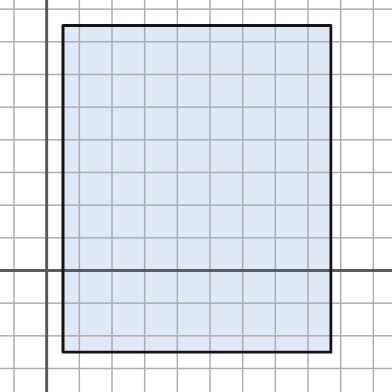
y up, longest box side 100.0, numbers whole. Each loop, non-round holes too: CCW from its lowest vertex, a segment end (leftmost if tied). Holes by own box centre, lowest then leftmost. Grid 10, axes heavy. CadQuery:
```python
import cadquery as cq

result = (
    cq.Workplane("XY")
    .moveTo(5.0, -25.0)
    .lineTo(87.0, -25.0)
    .lineTo(87.0, 75.0)
    .lineTo(5.0, 75.0)
    .close()
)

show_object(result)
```